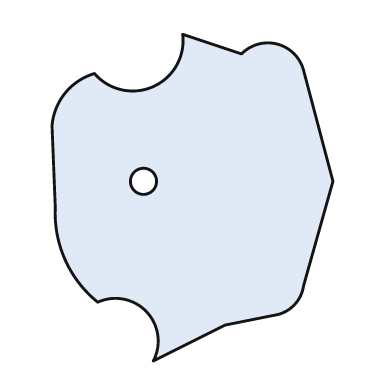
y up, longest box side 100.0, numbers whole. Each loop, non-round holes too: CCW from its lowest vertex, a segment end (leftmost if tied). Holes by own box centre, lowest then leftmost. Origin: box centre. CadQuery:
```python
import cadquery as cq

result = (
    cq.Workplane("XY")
    .moveTo(-12.0, -50.0)
    .lineTo(10.0, -39.0)
    .lineTo(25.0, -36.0)
    .threePointArc((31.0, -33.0), (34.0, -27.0))
    .lineTo(43.0, 5.0)
    .lineTo(34.0, 39.0)
    .threePointArc((26.0, 47.0), (15.0, 44.0))
    .lineTo(-3.0, 50.0)
    .threePointArc((-12.0, 34.0), (-30.0, 38.0))
    .threePointArc((-39.0, 32.0), (-43.0, 22.0))
    .lineTo(-42.0, -3.0)
    .threePointArc((-39.0, -19.0), (-29.0, -32.0))
    .threePointArc((-14.0, -35.0), (-12.0, -50.0))
    .close()
    .moveTo(-15.0, 5.0)
    .circle(4.0)
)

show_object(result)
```